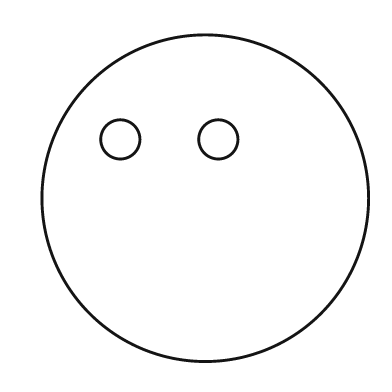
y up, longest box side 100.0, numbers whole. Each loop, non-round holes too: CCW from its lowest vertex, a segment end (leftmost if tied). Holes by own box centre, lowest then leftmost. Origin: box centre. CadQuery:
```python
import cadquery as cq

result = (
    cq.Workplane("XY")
    .moveTo(0.0, 0.0)
    .circle(50.0)
    .moveTo(-26.0, 18.0)
    .circle(6.0)
    .moveTo(4.0, 18.0)
    .circle(6.0)
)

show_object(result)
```